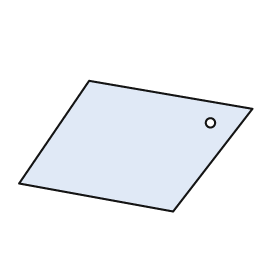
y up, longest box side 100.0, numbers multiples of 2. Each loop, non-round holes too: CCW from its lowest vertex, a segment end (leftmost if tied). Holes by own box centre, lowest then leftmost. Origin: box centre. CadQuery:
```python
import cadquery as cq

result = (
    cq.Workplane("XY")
    .moveTo(16.0, -28.0)
    .lineTo(50.0, 16.0)
    .lineTo(-20.0, 28.0)
    .lineTo(-50.0, -16.0)
    .close()
    .moveTo(32.0, 10.0)
    .circle(2.0)
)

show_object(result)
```